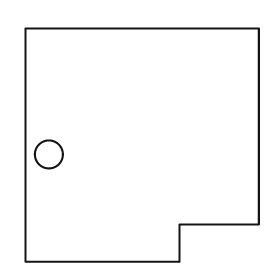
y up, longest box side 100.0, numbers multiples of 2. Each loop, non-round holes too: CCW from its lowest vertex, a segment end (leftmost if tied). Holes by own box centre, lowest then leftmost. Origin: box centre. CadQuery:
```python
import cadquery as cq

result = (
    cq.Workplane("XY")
    .moveTo(-50.0, -50.0)
    .lineTo(16.0, -50.0)
    .lineTo(16.0, -34.0)
    .lineTo(50.0, -34.0)
    .lineTo(50.0, 50.0)
    .lineTo(-50.0, 50.0)
    .close()
    .moveTo(-40.0, -4.0)
    .circle(6.0)
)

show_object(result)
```